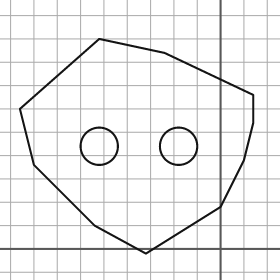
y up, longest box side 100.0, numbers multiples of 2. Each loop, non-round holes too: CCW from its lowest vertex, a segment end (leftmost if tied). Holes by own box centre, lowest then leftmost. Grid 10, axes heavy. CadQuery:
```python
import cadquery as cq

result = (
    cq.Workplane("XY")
    .moveTo(-32.0, -2.0)
    .lineTo(0.0, 18.0)
    .lineTo(10.0, 38.0)
    .lineTo(14.0, 54.0)
    .lineTo(14.0, 66.0)
    .lineTo(-24.0, 84.0)
    .lineTo(-52.0, 90.0)
    .lineTo(-86.0, 60.0)
    .lineTo(-80.0, 36.0)
    .lineTo(-54.0, 10.0)
    .close()
    .moveTo(-52.0, 44.0)
    .circle(8.0)
    .moveTo(-18.0, 44.0)
    .circle(8.0)
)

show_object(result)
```